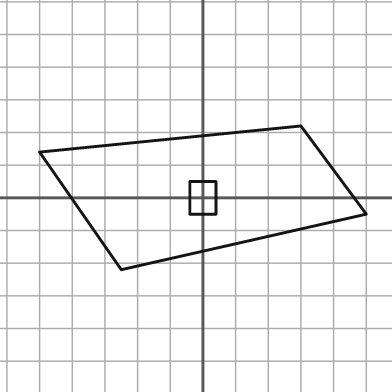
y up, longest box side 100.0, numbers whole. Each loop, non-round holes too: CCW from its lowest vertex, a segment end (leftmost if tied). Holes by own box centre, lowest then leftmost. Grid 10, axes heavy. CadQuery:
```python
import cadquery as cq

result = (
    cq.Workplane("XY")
    .moveTo(-25.0, -22.0)
    .lineTo(50.0, -5.0)
    .lineTo(30.0, 22.0)
    .lineTo(-50.0, 14.0)
    .close()
    .moveTo(-4.0, -5.0)
    .lineTo(4.0, -5.0)
    .lineTo(4.0, 5.0)
    .lineTo(-4.0, 5.0)
    .close()
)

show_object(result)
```